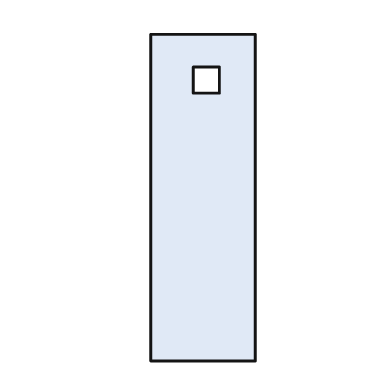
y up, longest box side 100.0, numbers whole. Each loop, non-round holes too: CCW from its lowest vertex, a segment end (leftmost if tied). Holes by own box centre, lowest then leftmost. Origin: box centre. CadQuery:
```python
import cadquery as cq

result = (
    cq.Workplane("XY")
    .moveTo(-16.0, -50.0)
    .lineTo(16.0, -50.0)
    .lineTo(16.0, 50.0)
    .lineTo(-16.0, 50.0)
    .close()
    .moveTo(-3.0, 32.0)
    .lineTo(5.0, 32.0)
    .lineTo(5.0, 40.0)
    .lineTo(-3.0, 40.0)
    .close()
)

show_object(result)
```